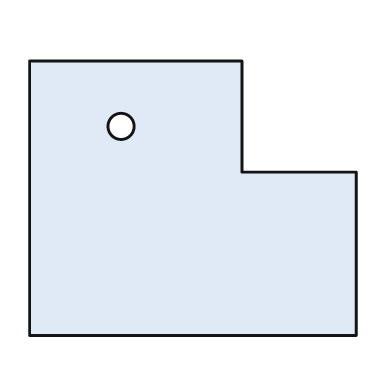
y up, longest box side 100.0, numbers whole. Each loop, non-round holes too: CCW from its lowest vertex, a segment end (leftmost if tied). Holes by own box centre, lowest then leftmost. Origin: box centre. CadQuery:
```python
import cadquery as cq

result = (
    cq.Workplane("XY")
    .moveTo(-50.0, -42.0)
    .lineTo(50.0, -42.0)
    .lineTo(50.0, 8.0)
    .lineTo(15.0, 8.0)
    .lineTo(15.0, 42.0)
    .lineTo(-50.0, 42.0)
    .close()
    .moveTo(-22.0, 22.0)
    .circle(4.0)
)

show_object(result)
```